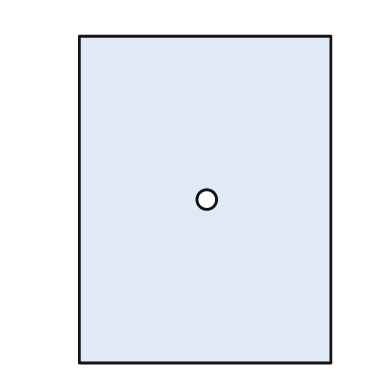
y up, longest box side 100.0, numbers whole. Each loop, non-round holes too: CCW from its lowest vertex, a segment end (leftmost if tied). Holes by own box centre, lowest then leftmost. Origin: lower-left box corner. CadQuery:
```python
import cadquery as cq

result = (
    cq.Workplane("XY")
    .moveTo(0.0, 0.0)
    .lineTo(77.0, 0.0)
    .lineTo(77.0, 100.0)
    .lineTo(0.0, 100.0)
    .close()
    .moveTo(39.0, 50.0)
    .circle(3.0)
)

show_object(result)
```